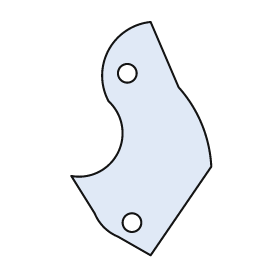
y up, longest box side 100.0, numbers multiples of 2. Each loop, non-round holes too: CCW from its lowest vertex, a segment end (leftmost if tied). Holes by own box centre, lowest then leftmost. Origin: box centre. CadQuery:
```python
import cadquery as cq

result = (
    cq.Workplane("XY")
    .moveTo(4.0, -50.0)
    .lineTo(30.0, -12.0)
    .threePointArc((26.0, 6.0), (16.0, 22.0))
    .lineTo(4.0, 50.0)
    .threePointArc((-14.0, 38.0), (-14.0, 16.0))
    .threePointArc((-10.0, -6.0), (-30.0, -16.0))
    .lineTo(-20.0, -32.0)
    .threePointArc((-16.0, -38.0), (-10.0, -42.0))
    .close()
    .moveTo(-4.0, -36.0)
    .circle(4.0)
    .moveTo(-6.0, 28.0)
    .circle(4.0)
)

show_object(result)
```